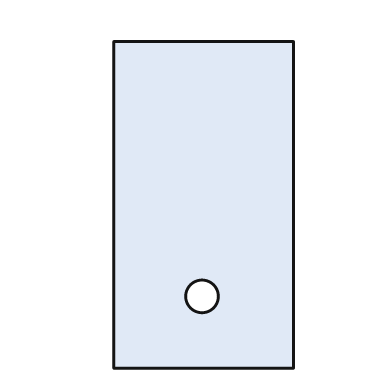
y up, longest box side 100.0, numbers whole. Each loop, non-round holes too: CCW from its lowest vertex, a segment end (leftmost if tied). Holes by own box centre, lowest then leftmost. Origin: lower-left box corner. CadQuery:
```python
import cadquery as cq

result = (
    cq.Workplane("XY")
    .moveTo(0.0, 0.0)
    .lineTo(55.0, 0.0)
    .lineTo(55.0, 100.0)
    .lineTo(0.0, 100.0)
    .close()
    .moveTo(27.0, 22.0)
    .circle(5.0)
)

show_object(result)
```